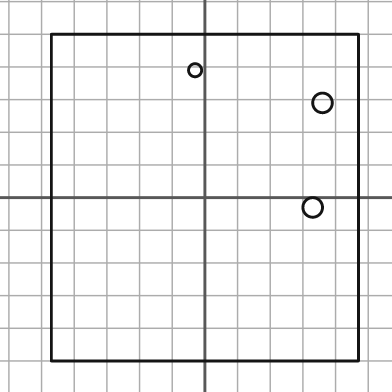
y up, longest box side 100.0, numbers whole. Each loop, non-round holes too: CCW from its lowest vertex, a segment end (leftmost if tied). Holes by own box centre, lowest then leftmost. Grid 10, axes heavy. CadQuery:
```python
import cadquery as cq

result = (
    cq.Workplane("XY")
    .moveTo(-47.0, -50.0)
    .lineTo(47.0, -50.0)
    .lineTo(47.0, 50.0)
    .lineTo(-47.0, 50.0)
    .close()
    .moveTo(33.0, -3.0)
    .circle(3.0)
    .moveTo(36.0, 29.0)
    .circle(3.0)
    .moveTo(-3.0, 39.0)
    .circle(2.0)
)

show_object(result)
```